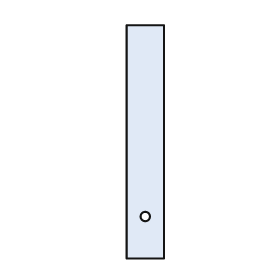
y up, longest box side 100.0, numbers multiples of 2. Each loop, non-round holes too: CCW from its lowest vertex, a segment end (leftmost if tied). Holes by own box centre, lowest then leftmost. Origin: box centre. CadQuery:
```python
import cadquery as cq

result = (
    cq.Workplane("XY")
    .moveTo(-8.0, -50.0)
    .lineTo(8.0, -50.0)
    .lineTo(8.0, 50.0)
    .lineTo(-8.0, 50.0)
    .close()
    .moveTo(0.0, -32.0)
    .circle(2.0)
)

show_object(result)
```